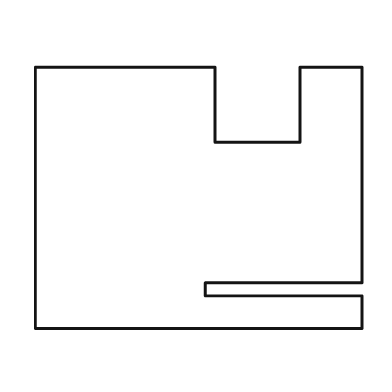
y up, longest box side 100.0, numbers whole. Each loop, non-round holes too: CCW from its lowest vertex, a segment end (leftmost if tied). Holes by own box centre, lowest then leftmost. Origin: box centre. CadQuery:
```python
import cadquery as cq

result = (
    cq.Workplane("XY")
    .moveTo(-50.0, -40.0)
    .lineTo(50.0, -40.0)
    .lineTo(50.0, -30.0)
    .lineTo(2.0, -30.0)
    .lineTo(2.0, -26.0)
    .lineTo(50.0, -26.0)
    .lineTo(50.0, 40.0)
    .lineTo(31.0, 40.0)
    .lineTo(31.0, 17.0)
    .lineTo(5.0, 17.0)
    .lineTo(5.0, 40.0)
    .lineTo(-50.0, 40.0)
    .close()
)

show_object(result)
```